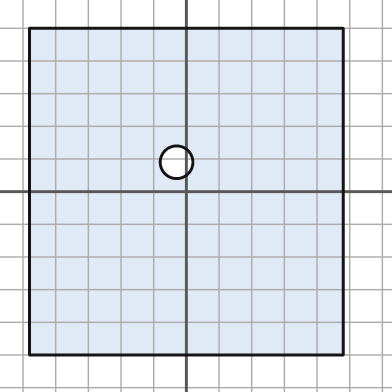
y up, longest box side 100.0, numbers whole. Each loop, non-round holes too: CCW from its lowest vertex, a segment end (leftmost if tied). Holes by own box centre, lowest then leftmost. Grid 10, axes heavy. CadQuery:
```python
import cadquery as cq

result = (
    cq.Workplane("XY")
    .moveTo(-48.0, -50.0)
    .lineTo(48.0, -50.0)
    .lineTo(48.0, 50.0)
    .lineTo(-48.0, 50.0)
    .close()
    .moveTo(-3.0, 9.0)
    .circle(5.0)
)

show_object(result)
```